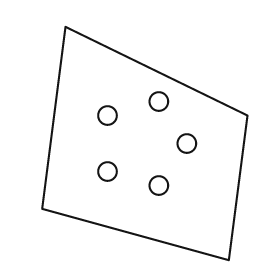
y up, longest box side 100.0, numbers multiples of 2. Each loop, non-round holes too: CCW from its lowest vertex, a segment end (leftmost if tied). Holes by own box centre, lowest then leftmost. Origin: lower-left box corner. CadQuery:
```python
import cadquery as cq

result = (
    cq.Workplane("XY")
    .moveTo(80.0, 0.0)
    .lineTo(88.0, 62.0)
    .lineTo(10.0, 100.0)
    .lineTo(0.0, 22.0)
    .close()
    .moveTo(50.0, 32.0)
    .circle(4.0)
    .moveTo(28.0, 38.0)
    .circle(4.0)
    .moveTo(62.0, 50.0)
    .circle(4.0)
    .moveTo(28.0, 62.0)
    .circle(4.0)
    .moveTo(50.0, 68.0)
    .circle(4.0)
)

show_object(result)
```